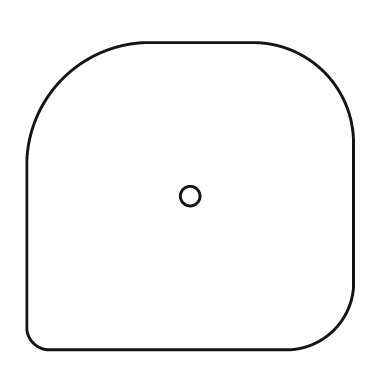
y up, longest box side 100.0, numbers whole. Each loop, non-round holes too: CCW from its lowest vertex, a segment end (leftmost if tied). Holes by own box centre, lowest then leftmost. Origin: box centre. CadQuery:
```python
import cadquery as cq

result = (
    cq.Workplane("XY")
    .moveTo(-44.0, -47.0)
    .lineTo(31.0, -47.0)
    .threePointArc((44.0, -41.0), (50.0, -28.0))
    .lineTo(50.0, 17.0)
    .threePointArc((41.0, 38.0), (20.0, 47.0))
    .lineTo(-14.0, 47.0)
    .threePointArc((-39.0, 36.0), (-50.0, 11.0))
    .lineTo(-50.0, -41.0)
    .threePointArc((-48.0, -45.0), (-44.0, -47.0))
    .close()
    .moveTo(0.0, 0.0)
    .circle(3.0)
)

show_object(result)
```